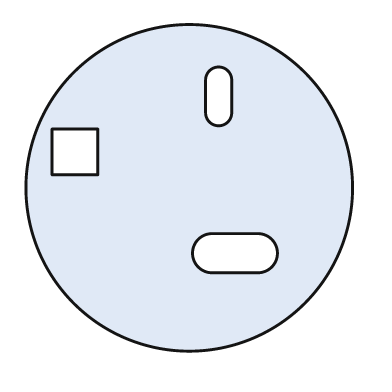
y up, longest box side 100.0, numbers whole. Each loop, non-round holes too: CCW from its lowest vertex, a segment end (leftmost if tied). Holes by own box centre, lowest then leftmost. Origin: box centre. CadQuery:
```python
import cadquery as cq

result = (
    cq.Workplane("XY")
    .moveTo(0.0, 0.0)
    .circle(50.0)
    .moveTo(7.0, -26.0)
    .lineTo(21.0, -26.0)
    .threePointArc((27.0, -20.0), (21.0, -14.0))
    .lineTo(7.0, -14.0)
    .threePointArc((1.0, -20.0), (7.0, -26.0))
    .close()
    .moveTo(-42.0, 4.0)
    .lineTo(-28.0, 4.0)
    .lineTo(-28.0, 18.0)
    .lineTo(-42.0, 18.0)
    .close()
    .moveTo(5.0, 23.0)
    .threePointArc((9.0, 19.0), (13.0, 23.0))
    .lineTo(13.0, 33.0)
    .threePointArc((9.0, 37.0), (5.0, 33.0))
    .close()
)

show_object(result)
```